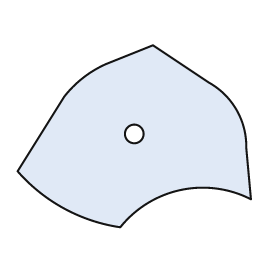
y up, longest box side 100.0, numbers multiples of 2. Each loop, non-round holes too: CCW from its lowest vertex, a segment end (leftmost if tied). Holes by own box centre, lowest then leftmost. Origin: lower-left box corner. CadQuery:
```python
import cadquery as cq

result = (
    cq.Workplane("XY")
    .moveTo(44.0, 0.0)
    .threePointArc((70.0, 16.0), (100.0, 12.0))
    .lineTo(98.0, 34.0)
    .threePointArc((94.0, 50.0), (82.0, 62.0))
    .lineTo(58.0, 78.0)
    .lineTo(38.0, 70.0)
    .threePointArc((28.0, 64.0), (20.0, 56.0))
    .lineTo(0.0, 24.0)
    .threePointArc((20.0, 8.0), (44.0, 0.0))
    .close()
    .moveTo(50.0, 40.0)
    .circle(4.0)
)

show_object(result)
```